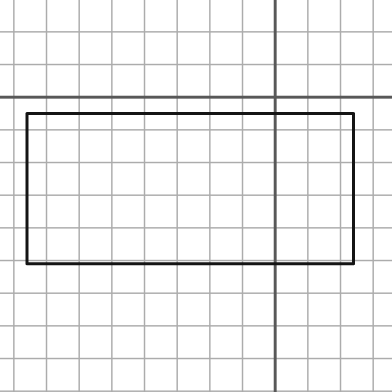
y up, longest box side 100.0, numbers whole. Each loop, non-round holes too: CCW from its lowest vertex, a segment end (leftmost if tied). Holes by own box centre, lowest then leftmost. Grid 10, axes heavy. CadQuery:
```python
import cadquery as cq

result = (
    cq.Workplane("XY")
    .moveTo(-76.0, -51.0)
    .lineTo(24.0, -51.0)
    .lineTo(24.0, -5.0)
    .lineTo(-76.0, -5.0)
    .close()
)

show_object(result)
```